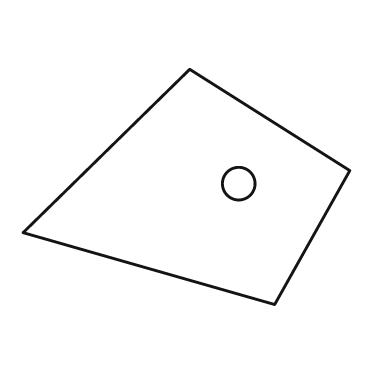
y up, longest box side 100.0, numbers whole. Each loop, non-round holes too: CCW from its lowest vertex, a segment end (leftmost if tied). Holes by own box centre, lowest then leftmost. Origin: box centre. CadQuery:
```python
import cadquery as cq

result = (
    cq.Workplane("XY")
    .moveTo(27.0, -36.0)
    .lineTo(50.0, 5.0)
    .lineTo(1.0, 36.0)
    .lineTo(-50.0, -14.0)
    .close()
    .moveTo(16.0, 1.0)
    .circle(5.0)
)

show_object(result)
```